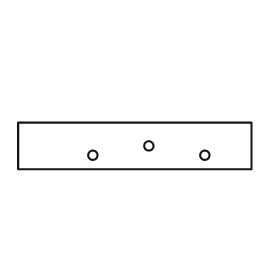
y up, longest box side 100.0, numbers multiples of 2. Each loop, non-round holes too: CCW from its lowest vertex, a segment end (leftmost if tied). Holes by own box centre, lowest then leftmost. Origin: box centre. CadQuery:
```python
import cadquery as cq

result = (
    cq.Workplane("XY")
    .moveTo(-50.0, -10.0)
    .lineTo(50.0, -10.0)
    .lineTo(50.0, 10.0)
    .lineTo(-50.0, 10.0)
    .close()
    .moveTo(-18.0, -4.0)
    .circle(2.0)
    .moveTo(30.0, -4.0)
    .circle(2.0)
    .moveTo(6.0, 0.0)
    .circle(2.0)
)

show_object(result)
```